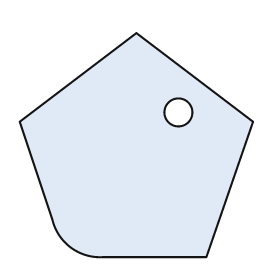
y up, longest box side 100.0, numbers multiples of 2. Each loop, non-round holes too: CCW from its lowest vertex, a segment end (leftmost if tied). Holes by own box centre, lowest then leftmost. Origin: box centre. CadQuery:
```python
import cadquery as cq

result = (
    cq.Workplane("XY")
    .moveTo(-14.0, -48.0)
    .lineTo(30.0, -48.0)
    .lineTo(50.0, 10.0)
    .lineTo(0.0, 48.0)
    .lineTo(-50.0, 10.0)
    .lineTo(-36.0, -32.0)
    .threePointArc((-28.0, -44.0), (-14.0, -48.0))
    .close()
    .moveTo(18.0, 14.0)
    .circle(6.0)
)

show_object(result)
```